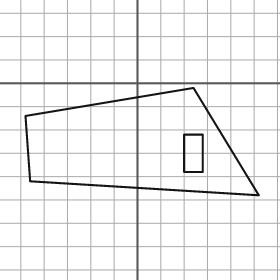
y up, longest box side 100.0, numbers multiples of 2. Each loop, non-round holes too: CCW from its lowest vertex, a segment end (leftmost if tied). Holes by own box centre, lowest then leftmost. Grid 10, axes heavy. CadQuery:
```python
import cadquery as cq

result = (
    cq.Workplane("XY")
    .moveTo(52.0, -48.0)
    .lineTo(24.0, -2.0)
    .lineTo(-48.0, -14.0)
    .lineTo(-46.0, -42.0)
    .close()
    .moveTo(20.0, -38.0)
    .lineTo(28.0, -38.0)
    .lineTo(28.0, -22.0)
    .lineTo(20.0, -22.0)
    .close()
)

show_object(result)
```